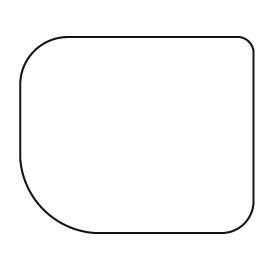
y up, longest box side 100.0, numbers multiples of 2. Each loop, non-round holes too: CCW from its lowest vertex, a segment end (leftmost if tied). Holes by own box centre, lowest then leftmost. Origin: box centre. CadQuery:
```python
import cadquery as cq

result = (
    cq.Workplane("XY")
    .moveTo(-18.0, -42.0)
    .lineTo(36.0, -42.0)
    .threePointArc((46.0, -38.0), (50.0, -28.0))
    .lineTo(50.0, 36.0)
    .threePointArc((48.0, 40.0), (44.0, 42.0))
    .lineTo(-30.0, 42.0)
    .threePointArc((-44.0, 36.0), (-50.0, 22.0))
    .lineTo(-50.0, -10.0)
    .threePointArc((-40.0, -32.0), (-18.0, -42.0))
    .close()
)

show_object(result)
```